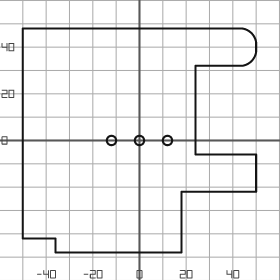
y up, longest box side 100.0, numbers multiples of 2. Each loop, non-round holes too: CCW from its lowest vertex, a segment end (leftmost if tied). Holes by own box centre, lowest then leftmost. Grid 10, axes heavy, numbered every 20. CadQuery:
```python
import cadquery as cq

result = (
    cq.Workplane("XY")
    .moveTo(-36.0, -48.0)
    .lineTo(18.0, -48.0)
    .lineTo(18.0, -22.0)
    .lineTo(50.0, -22.0)
    .lineTo(50.0, -6.0)
    .lineTo(24.0, -6.0)
    .lineTo(24.0, 32.0)
    .lineTo(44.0, 32.0)
    .threePointArc((48.0, 34.0), (50.0, 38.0))
    .lineTo(50.0, 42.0)
    .threePointArc((48.0, 46.0), (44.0, 48.0))
    .lineTo(-50.0, 48.0)
    .lineTo(-50.0, -42.0)
    .lineTo(-36.0, -42.0)
    .close()
    .moveTo(-12.0, 0.0)
    .circle(2.0)
    .moveTo(0.0, 0.0)
    .circle(2.0)
    .moveTo(12.0, 0.0)
    .circle(2.0)
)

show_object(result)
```